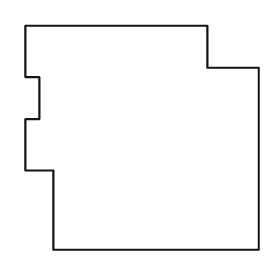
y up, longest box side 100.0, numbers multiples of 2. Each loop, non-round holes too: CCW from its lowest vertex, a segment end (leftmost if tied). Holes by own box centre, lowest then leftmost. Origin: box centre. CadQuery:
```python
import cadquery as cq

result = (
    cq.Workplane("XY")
    .moveTo(-38.0, -48.0)
    .lineTo(50.0, -48.0)
    .lineTo(50.0, 30.0)
    .lineTo(28.0, 30.0)
    .lineTo(28.0, 48.0)
    .lineTo(-50.0, 48.0)
    .lineTo(-50.0, 26.0)
    .lineTo(-44.0, 26.0)
    .lineTo(-44.0, 8.0)
    .lineTo(-50.0, 8.0)
    .lineTo(-50.0, -14.0)
    .lineTo(-38.0, -14.0)
    .close()
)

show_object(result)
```